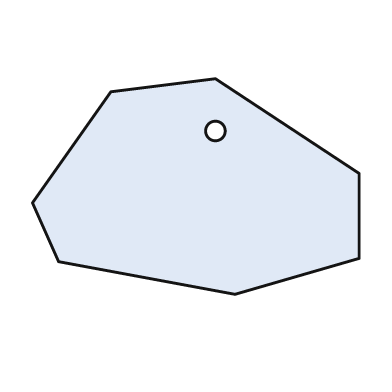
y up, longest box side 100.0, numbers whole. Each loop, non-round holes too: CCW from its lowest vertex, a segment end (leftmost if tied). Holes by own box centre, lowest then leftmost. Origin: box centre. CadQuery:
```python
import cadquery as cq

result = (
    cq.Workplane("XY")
    .moveTo(12.0, -33.0)
    .lineTo(50.0, -22.0)
    .lineTo(50.0, 4.0)
    .lineTo(6.0, 33.0)
    .lineTo(-26.0, 29.0)
    .lineTo(-50.0, -5.0)
    .lineTo(-42.0, -23.0)
    .close()
    .moveTo(6.0, 17.0)
    .circle(3.0)
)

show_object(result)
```